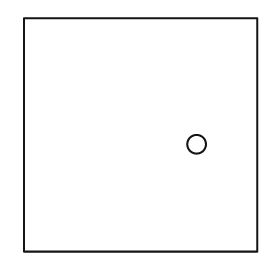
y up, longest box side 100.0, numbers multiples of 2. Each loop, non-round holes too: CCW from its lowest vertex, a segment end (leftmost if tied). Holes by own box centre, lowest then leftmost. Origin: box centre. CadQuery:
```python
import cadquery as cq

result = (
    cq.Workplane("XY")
    .moveTo(-50.0, -50.0)
    .lineTo(50.0, -50.0)
    .lineTo(50.0, 50.0)
    .lineTo(-50.0, 50.0)
    .close()
    .moveTo(24.0, -4.0)
    .circle(4.0)
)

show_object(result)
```